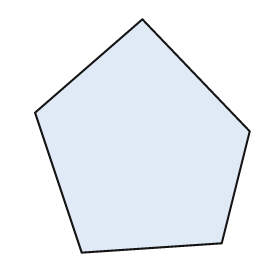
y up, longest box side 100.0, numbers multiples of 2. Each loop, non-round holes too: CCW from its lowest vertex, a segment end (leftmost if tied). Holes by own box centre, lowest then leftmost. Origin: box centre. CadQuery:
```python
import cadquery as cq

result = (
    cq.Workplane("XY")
    .moveTo(-26.0, -50.0)
    .lineTo(34.0, -46.0)
    .lineTo(46.0, 2.0)
    .lineTo(0.0, 50.0)
    .lineTo(-46.0, 10.0)
    .close()
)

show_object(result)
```